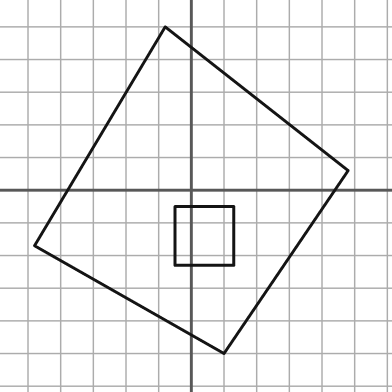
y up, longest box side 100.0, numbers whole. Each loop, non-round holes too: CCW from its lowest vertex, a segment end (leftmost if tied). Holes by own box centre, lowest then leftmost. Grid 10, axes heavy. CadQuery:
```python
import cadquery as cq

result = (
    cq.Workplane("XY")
    .moveTo(10.0, -50.0)
    .lineTo(48.0, 6.0)
    .lineTo(-8.0, 50.0)
    .lineTo(-48.0, -17.0)
    .close()
    .moveTo(-5.0, -23.0)
    .lineTo(13.0, -23.0)
    .lineTo(13.0, -5.0)
    .lineTo(-5.0, -5.0)
    .close()
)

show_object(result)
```